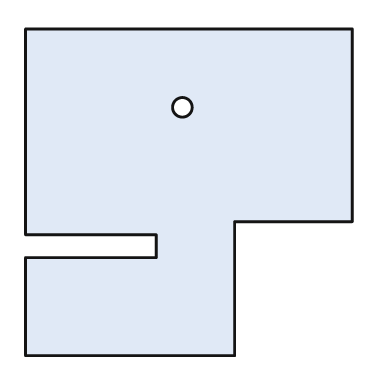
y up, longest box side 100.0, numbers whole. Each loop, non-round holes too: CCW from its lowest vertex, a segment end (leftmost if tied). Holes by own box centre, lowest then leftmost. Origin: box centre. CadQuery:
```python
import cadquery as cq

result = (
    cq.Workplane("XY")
    .moveTo(-50.0, -50.0)
    .lineTo(14.0, -50.0)
    .lineTo(14.0, -9.0)
    .lineTo(50.0, -9.0)
    .lineTo(50.0, 50.0)
    .lineTo(-50.0, 50.0)
    .lineTo(-50.0, -13.0)
    .lineTo(-10.0, -13.0)
    .lineTo(-10.0, -20.0)
    .lineTo(-50.0, -20.0)
    .close()
    .moveTo(-2.0, 26.0)
    .circle(3.0)
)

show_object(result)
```